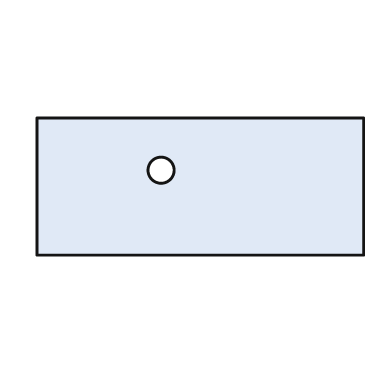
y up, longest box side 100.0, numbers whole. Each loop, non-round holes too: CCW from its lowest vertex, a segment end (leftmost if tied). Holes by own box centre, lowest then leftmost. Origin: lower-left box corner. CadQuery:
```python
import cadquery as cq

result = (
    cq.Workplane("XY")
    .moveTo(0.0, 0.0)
    .lineTo(100.0, 0.0)
    .lineTo(100.0, 42.0)
    .lineTo(0.0, 42.0)
    .close()
    .moveTo(38.0, 26.0)
    .circle(4.0)
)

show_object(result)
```